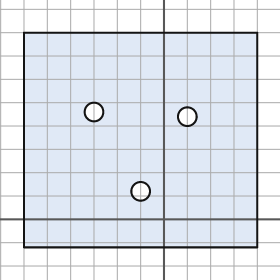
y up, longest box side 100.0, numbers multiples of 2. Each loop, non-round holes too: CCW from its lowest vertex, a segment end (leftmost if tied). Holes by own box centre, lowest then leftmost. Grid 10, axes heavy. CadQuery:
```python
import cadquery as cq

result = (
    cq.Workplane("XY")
    .moveTo(-60.0, -12.0)
    .lineTo(40.0, -12.0)
    .lineTo(40.0, 80.0)
    .lineTo(-60.0, 80.0)
    .close()
    .moveTo(-10.0, 12.0)
    .circle(4.0)
    .moveTo(10.0, 44.0)
    .circle(4.0)
    .moveTo(-30.0, 46.0)
    .circle(4.0)
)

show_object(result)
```